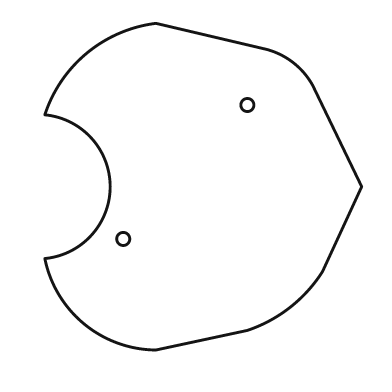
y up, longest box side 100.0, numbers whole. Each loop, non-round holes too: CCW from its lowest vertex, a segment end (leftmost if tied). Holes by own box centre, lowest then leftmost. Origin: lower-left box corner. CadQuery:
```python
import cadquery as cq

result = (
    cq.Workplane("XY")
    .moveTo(34.0, 0.0)
    .lineTo(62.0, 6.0)
    .threePointArc((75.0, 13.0), (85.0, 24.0))
    .lineTo(97.0, 50.0)
    .lineTo(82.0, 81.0)
    .threePointArc((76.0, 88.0), (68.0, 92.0))
    .lineTo(34.0, 100.0)
    .threePointArc((13.0, 91.0), (0.0, 72.0))
    .threePointArc((20.0, 50.0), (0.0, 28.0))
    .threePointArc((12.0, 8.0), (34.0, 0.0))
    .close()
    .moveTo(24.0, 34.0)
    .circle(2.0)
    .moveTo(62.0, 75.0)
    .circle(2.0)
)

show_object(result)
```